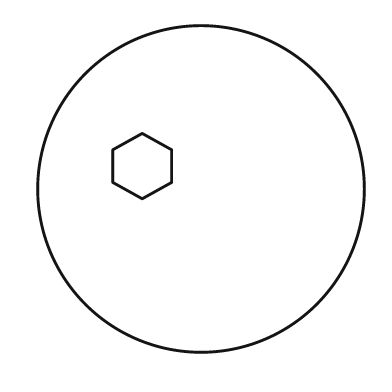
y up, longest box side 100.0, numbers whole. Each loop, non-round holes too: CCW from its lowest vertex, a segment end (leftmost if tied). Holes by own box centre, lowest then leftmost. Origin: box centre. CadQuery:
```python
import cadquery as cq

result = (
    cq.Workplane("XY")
    .moveTo(0.0, 0.0)
    .circle(50.0)
    .moveTo(-18.0, -3.0)
    .lineTo(-9.0, 2.0)
    .lineTo(-9.0, 12.0)
    .lineTo(-18.0, 17.0)
    .lineTo(-27.0, 12.0)
    .lineTo(-27.0, 2.0)
    .close()
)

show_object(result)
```